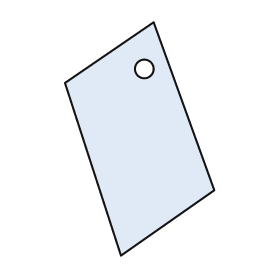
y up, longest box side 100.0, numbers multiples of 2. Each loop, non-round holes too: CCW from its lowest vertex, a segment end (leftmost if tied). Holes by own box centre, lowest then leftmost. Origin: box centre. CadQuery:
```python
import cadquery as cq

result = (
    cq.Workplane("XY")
    .moveTo(-8.0, -50.0)
    .lineTo(32.0, -22.0)
    .lineTo(6.0, 50.0)
    .lineTo(-32.0, 24.0)
    .close()
    .moveTo(2.0, 30.0)
    .circle(4.0)
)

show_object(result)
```